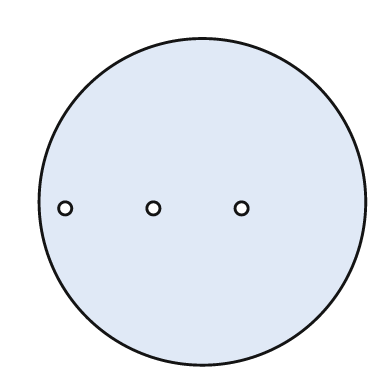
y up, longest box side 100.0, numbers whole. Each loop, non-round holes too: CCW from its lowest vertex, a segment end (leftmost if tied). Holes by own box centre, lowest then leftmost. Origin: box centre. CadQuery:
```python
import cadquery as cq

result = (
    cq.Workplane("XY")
    .moveTo(0.0, 0.0)
    .circle(50.0)
    .moveTo(-42.0, -2.0)
    .circle(2.0)
    .moveTo(-15.0, -2.0)
    .circle(2.0)
    .moveTo(12.0, -2.0)
    .circle(2.0)
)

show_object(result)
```